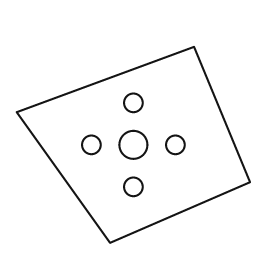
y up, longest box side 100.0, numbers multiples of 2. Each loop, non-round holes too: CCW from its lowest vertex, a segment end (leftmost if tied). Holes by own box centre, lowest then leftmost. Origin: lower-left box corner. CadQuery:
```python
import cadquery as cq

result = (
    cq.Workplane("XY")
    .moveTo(40.0, 0.0)
    .lineTo(100.0, 26.0)
    .lineTo(76.0, 84.0)
    .lineTo(0.0, 56.0)
    .close()
    .moveTo(50.0, 24.0)
    .circle(4.0)
    .moveTo(32.0, 42.0)
    .circle(4.0)
    .moveTo(50.0, 42.0)
    .circle(6.0)
    .moveTo(68.0, 42.0)
    .circle(4.0)
    .moveTo(50.0, 60.0)
    .circle(4.0)
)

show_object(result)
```